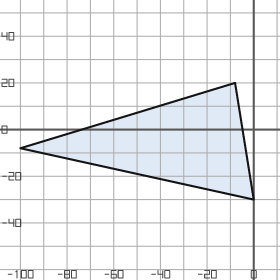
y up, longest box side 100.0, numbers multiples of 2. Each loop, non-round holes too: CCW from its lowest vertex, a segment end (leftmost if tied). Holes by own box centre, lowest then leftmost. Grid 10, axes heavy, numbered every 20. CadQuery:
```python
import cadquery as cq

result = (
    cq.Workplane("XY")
    .moveTo(0.0, -30.0)
    .lineTo(-8.0, 20.0)
    .lineTo(-100.0, -8.0)
    .close()
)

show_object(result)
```